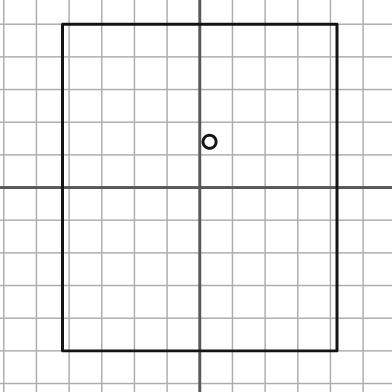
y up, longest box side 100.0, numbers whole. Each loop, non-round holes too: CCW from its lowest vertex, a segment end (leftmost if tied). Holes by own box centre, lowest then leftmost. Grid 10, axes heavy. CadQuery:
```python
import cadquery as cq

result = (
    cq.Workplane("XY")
    .moveTo(-42.0, -50.0)
    .lineTo(42.0, -50.0)
    .lineTo(42.0, 50.0)
    .lineTo(-42.0, 50.0)
    .close()
    .moveTo(3.0, 14.0)
    .circle(2.0)
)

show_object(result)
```